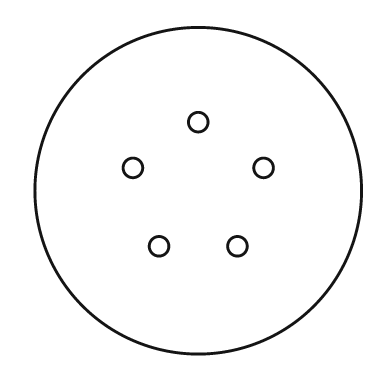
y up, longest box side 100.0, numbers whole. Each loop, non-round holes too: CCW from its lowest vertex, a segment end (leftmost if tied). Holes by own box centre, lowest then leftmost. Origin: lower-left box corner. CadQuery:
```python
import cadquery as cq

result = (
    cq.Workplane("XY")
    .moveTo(50.0, 50.0)
    .circle(50.0)
    .moveTo(38.0, 33.0)
    .circle(3.0)
    .moveTo(62.0, 33.0)
    .circle(3.0)
    .moveTo(30.0, 57.0)
    .circle(3.0)
    .moveTo(70.0, 57.0)
    .circle(3.0)
    .moveTo(50.0, 71.0)
    .circle(3.0)
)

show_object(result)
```